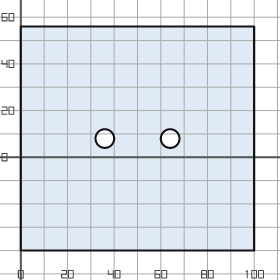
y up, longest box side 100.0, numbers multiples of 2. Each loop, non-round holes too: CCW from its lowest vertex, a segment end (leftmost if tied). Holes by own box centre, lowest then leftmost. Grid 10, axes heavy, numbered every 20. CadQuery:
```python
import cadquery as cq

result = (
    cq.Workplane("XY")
    .moveTo(0.0, -40.0)
    .lineTo(100.0, -40.0)
    .lineTo(100.0, 56.0)
    .lineTo(0.0, 56.0)
    .close()
    .moveTo(36.0, 8.0)
    .circle(4.0)
    .moveTo(64.0, 8.0)
    .circle(4.0)
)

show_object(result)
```